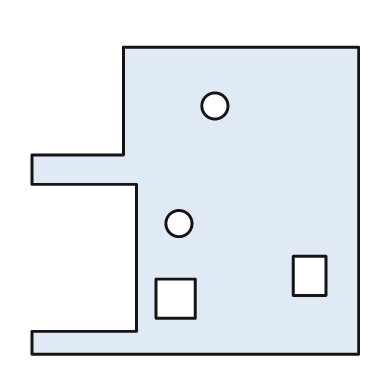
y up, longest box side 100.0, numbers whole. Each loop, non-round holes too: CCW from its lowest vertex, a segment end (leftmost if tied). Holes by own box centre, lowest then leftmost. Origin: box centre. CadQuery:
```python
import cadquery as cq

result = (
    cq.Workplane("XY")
    .moveTo(-50.0, -47.0)
    .lineTo(50.0, -47.0)
    .lineTo(50.0, 47.0)
    .lineTo(-22.0, 47.0)
    .lineTo(-22.0, 14.0)
    .lineTo(-50.0, 14.0)
    .lineTo(-50.0, 5.0)
    .lineTo(-18.0, 5.0)
    .lineTo(-18.0, -40.0)
    .lineTo(-50.0, -40.0)
    .close()
    .moveTo(-12.0, -36.0)
    .lineTo(0.0, -36.0)
    .lineTo(0.0, -24.0)
    .lineTo(-12.0, -24.0)
    .close()
    .moveTo(30.0, -29.0)
    .lineTo(40.0, -29.0)
    .lineTo(40.0, -17.0)
    .lineTo(30.0, -17.0)
    .close()
    .moveTo(-5.0, -7.0)
    .circle(4.0)
    .moveTo(6.0, 29.0)
    .circle(4.0)
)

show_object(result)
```